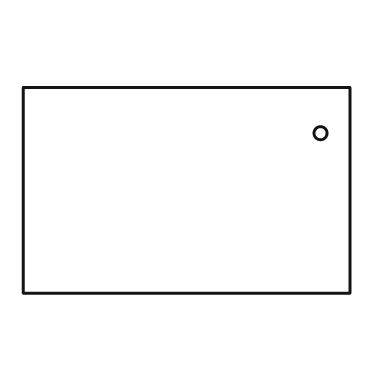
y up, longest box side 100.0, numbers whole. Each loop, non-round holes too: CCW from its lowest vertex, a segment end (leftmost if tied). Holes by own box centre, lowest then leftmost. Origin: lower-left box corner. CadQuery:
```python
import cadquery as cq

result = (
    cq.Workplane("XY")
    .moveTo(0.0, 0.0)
    .lineTo(100.0, 0.0)
    .lineTo(100.0, 63.0)
    .lineTo(0.0, 63.0)
    .close()
    .moveTo(91.0, 49.0)
    .circle(2.0)
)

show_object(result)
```